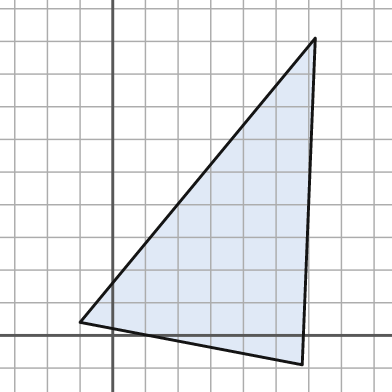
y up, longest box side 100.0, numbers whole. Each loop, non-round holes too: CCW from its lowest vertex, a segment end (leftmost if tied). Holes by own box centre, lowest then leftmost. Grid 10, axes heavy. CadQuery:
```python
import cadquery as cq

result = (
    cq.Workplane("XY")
    .moveTo(58.0, -9.0)
    .lineTo(62.0, 91.0)
    .lineTo(-10.0, 4.0)
    .close()
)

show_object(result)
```